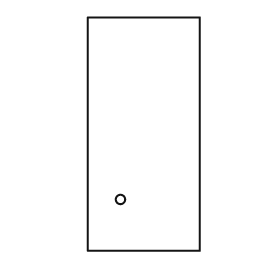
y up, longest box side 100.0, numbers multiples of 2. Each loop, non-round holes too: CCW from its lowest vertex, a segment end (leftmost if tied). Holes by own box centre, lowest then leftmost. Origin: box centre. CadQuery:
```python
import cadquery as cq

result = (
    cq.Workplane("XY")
    .moveTo(-24.0, -50.0)
    .lineTo(24.0, -50.0)
    .lineTo(24.0, 50.0)
    .lineTo(-24.0, 50.0)
    .close()
    .moveTo(-10.0, -28.0)
    .circle(2.0)
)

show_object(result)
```